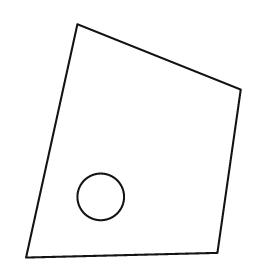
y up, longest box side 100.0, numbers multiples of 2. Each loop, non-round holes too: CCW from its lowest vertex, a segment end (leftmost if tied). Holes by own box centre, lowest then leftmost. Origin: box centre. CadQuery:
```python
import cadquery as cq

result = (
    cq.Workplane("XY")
    .moveTo(-46.0, -50.0)
    .lineTo(36.0, -48.0)
    .lineTo(46.0, 22.0)
    .lineTo(-24.0, 50.0)
    .close()
    .moveTo(-14.0, -24.0)
    .circle(10.0)
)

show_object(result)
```